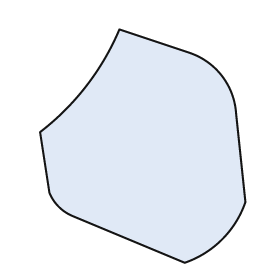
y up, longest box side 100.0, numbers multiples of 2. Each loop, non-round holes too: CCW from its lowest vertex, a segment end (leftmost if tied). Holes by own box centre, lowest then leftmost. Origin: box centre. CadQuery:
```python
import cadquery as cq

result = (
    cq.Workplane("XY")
    .moveTo(18.0, -50.0)
    .threePointArc((34.0, -40.0), (44.0, -24.0))
    .lineTo(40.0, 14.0)
    .threePointArc((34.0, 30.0), (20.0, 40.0))
    .lineTo(-10.0, 50.0)
    .threePointArc((-24.0, 26.0), (-44.0, 6.0))
    .lineTo(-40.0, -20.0)
    .threePointArc((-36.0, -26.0), (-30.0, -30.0))
    .close()
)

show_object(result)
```